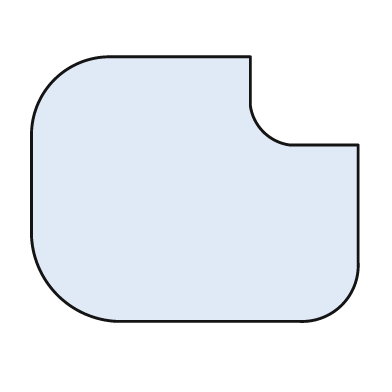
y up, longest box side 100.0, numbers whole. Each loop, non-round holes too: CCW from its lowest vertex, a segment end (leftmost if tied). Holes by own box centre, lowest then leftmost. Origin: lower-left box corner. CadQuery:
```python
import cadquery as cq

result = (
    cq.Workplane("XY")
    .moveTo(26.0, 0.0)
    .lineTo(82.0, 0.0)
    .threePointArc((95.0, 5.0), (100.0, 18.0))
    .lineTo(100.0, 54.0)
    .lineTo(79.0, 54.0)
    .threePointArc((71.0, 58.0), (67.0, 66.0))
    .lineTo(67.0, 81.0)
    .lineTo(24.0, 81.0)
    .threePointArc((7.0, 74.0), (0.0, 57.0))
    .lineTo(0.0, 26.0)
    .threePointArc((8.0, 8.0), (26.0, 0.0))
    .close()
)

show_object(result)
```